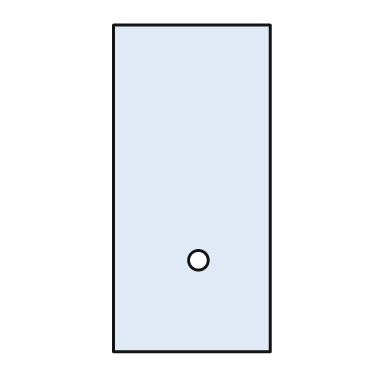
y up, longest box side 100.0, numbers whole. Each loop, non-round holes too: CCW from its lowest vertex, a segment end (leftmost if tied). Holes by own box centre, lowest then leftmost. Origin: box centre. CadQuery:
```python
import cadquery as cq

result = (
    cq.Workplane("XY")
    .moveTo(-24.0, -50.0)
    .lineTo(24.0, -50.0)
    .lineTo(24.0, 50.0)
    .lineTo(-24.0, 50.0)
    .close()
    .moveTo(2.0, -22.0)
    .circle(3.0)
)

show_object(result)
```